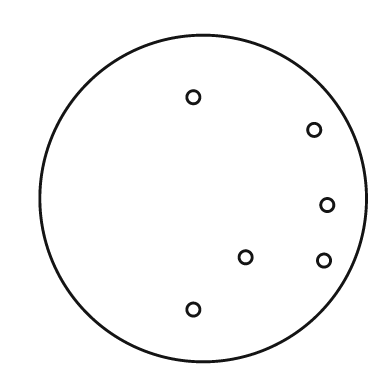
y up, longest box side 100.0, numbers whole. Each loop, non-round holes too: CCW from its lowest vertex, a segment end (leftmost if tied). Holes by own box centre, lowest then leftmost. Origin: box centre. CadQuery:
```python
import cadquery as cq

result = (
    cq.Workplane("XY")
    .moveTo(0.0, 0.0)
    .circle(50.0)
    .moveTo(-3.0, -34.0)
    .circle(2.0)
    .moveTo(37.0, -19.0)
    .circle(2.0)
    .moveTo(13.0, -18.0)
    .circle(2.0)
    .moveTo(38.0, -2.0)
    .circle(2.0)
    .moveTo(34.0, 21.0)
    .circle(2.0)
    .moveTo(-3.0, 31.0)
    .circle(2.0)
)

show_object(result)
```